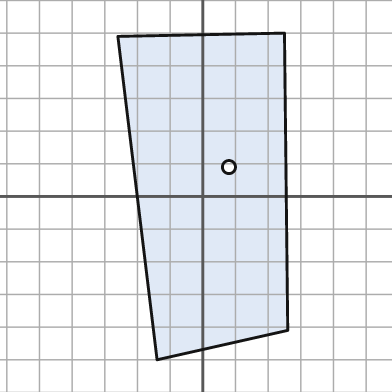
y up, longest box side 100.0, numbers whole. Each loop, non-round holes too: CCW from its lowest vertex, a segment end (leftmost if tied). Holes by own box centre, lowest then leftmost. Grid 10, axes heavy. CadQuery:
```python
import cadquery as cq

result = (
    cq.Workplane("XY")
    .moveTo(-14.0, -50.0)
    .lineTo(26.0, -41.0)
    .lineTo(25.0, 50.0)
    .lineTo(-26.0, 49.0)
    .close()
    .moveTo(8.0, 9.0)
    .circle(2.0)
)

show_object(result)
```